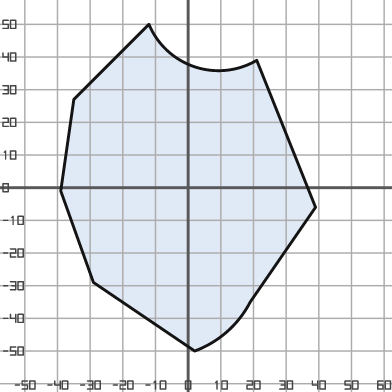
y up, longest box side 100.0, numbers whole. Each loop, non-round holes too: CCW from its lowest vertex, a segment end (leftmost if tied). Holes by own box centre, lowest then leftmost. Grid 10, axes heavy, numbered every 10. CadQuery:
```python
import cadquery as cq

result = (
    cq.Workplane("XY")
    .moveTo(2.0, -50.0)
    .threePointArc((12.0, -44.0), (19.0, -35.0))
    .lineTo(39.0, -6.0)
    .lineTo(21.0, 39.0)
    .threePointArc((2.0, 37.0), (-12.0, 50.0))
    .lineTo(-35.0, 27.0)
    .lineTo(-39.0, -1.0)
    .lineTo(-29.0, -29.0)
    .close()
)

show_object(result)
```